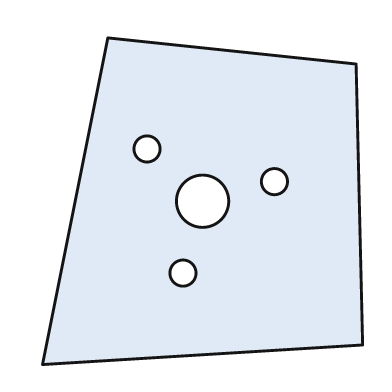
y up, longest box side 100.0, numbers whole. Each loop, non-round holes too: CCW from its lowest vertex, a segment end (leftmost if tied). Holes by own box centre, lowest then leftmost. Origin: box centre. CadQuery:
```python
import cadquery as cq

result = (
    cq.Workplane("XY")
    .moveTo(-49.0, -50.0)
    .lineTo(49.0, -44.0)
    .lineTo(47.0, 42.0)
    .lineTo(-29.0, 50.0)
    .close()
    .moveTo(-6.0, -22.0)
    .circle(4.0)
    .moveTo(0.0, 0.0)
    .circle(8.0)
    .moveTo(22.0, 6.0)
    .circle(4.0)
    .moveTo(-17.0, 16.0)
    .circle(4.0)
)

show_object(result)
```